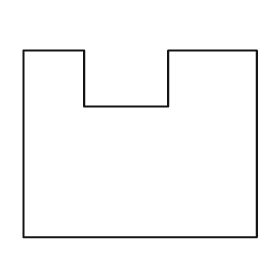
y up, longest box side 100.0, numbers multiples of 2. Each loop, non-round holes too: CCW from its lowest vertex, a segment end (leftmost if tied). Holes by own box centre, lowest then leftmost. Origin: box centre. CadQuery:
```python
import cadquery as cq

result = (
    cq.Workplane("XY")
    .moveTo(-50.0, -40.0)
    .lineTo(50.0, -40.0)
    .lineTo(50.0, 40.0)
    .lineTo(12.0, 40.0)
    .lineTo(12.0, 16.0)
    .lineTo(-24.0, 16.0)
    .lineTo(-24.0, 40.0)
    .lineTo(-50.0, 40.0)
    .close()
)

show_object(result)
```